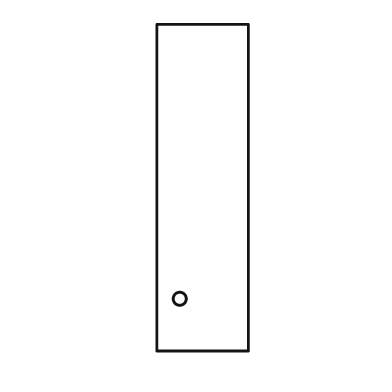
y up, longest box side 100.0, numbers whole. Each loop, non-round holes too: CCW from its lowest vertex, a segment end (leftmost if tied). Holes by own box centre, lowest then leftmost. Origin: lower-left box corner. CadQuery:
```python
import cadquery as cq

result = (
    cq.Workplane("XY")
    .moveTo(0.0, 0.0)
    .lineTo(28.0, 0.0)
    .lineTo(28.0, 100.0)
    .lineTo(0.0, 100.0)
    .close()
    .moveTo(7.0, 16.0)
    .circle(2.0)
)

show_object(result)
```